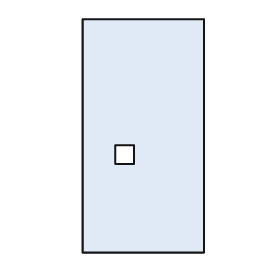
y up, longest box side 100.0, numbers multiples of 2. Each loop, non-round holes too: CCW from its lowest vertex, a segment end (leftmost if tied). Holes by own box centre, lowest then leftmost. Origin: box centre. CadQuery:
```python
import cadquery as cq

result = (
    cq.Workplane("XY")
    .moveTo(-26.0, -50.0)
    .lineTo(26.0, -50.0)
    .lineTo(26.0, 50.0)
    .lineTo(-26.0, 50.0)
    .close()
    .moveTo(-12.0, -12.0)
    .lineTo(-4.0, -12.0)
    .lineTo(-4.0, -4.0)
    .lineTo(-12.0, -4.0)
    .close()
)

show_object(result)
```